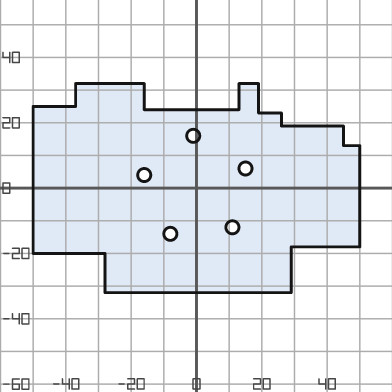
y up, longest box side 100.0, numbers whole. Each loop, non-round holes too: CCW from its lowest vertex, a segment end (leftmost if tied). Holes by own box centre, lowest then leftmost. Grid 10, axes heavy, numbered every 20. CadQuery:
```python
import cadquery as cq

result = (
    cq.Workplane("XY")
    .moveTo(-28.0, -32.0)
    .lineTo(29.0, -32.0)
    .lineTo(29.0, -18.0)
    .lineTo(50.0, -18.0)
    .lineTo(50.0, 13.0)
    .lineTo(45.0, 13.0)
    .lineTo(45.0, 19.0)
    .lineTo(26.0, 19.0)
    .lineTo(26.0, 23.0)
    .lineTo(19.0, 23.0)
    .lineTo(19.0, 32.0)
    .lineTo(13.0, 32.0)
    .lineTo(13.0, 24.0)
    .lineTo(-16.0, 24.0)
    .lineTo(-16.0, 32.0)
    .lineTo(-37.0, 32.0)
    .lineTo(-37.0, 25.0)
    .lineTo(-50.0, 25.0)
    .lineTo(-50.0, -20.0)
    .lineTo(-28.0, -20.0)
    .close()
    .moveTo(-8.0, -14.0)
    .circle(2.0)
    .moveTo(11.0, -12.0)
    .circle(2.0)
    .moveTo(-16.0, 4.0)
    .circle(2.0)
    .moveTo(15.0, 6.0)
    .circle(2.0)
    .moveTo(-1.0, 16.0)
    .circle(2.0)
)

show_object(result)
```